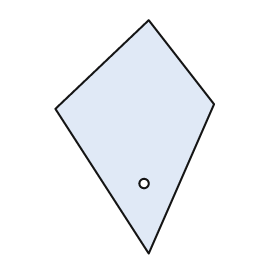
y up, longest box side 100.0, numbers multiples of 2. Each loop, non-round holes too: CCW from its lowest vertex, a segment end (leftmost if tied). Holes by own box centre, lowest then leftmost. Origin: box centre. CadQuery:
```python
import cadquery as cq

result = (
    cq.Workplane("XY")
    .moveTo(6.0, -50.0)
    .lineTo(34.0, 14.0)
    .lineTo(6.0, 50.0)
    .lineTo(-34.0, 12.0)
    .close()
    .moveTo(4.0, -20.0)
    .circle(2.0)
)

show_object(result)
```